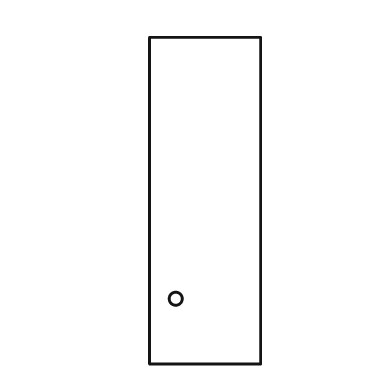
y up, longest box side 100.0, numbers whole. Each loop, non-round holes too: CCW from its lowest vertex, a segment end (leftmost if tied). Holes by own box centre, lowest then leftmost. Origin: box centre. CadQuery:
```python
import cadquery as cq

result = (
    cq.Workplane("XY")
    .moveTo(-17.0, -50.0)
    .lineTo(17.0, -50.0)
    .lineTo(17.0, 50.0)
    .lineTo(-17.0, 50.0)
    .close()
    .moveTo(-9.0, -30.0)
    .circle(2.0)
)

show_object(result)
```